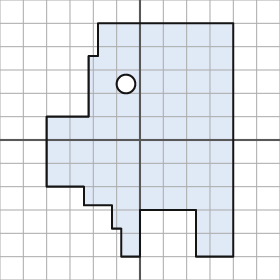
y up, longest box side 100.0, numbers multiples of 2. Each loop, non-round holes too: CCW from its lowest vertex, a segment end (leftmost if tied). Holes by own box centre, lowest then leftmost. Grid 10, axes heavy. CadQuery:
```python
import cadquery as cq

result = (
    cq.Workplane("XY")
    .moveTo(-8.0, -50.0)
    .lineTo(0.0, -50.0)
    .lineTo(0.0, -30.0)
    .lineTo(24.0, -30.0)
    .lineTo(24.0, -50.0)
    .lineTo(40.0, -50.0)
    .lineTo(40.0, 50.0)
    .lineTo(-18.0, 50.0)
    .lineTo(-18.0, 36.0)
    .lineTo(-22.0, 36.0)
    .lineTo(-22.0, 10.0)
    .lineTo(-40.0, 10.0)
    .lineTo(-40.0, -20.0)
    .lineTo(-24.0, -20.0)
    .lineTo(-24.0, -28.0)
    .lineTo(-12.0, -28.0)
    .lineTo(-12.0, -38.0)
    .lineTo(-8.0, -38.0)
    .close()
    .moveTo(-6.0, 24.0)
    .circle(4.0)
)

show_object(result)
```